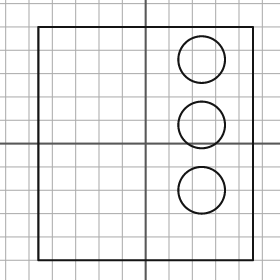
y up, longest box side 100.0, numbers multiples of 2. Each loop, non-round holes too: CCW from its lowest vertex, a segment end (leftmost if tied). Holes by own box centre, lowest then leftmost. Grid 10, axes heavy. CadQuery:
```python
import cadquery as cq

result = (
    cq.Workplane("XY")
    .moveTo(-46.0, -50.0)
    .lineTo(46.0, -50.0)
    .lineTo(46.0, 50.0)
    .lineTo(-46.0, 50.0)
    .close()
    .moveTo(24.0, -20.0)
    .circle(10.0)
    .moveTo(24.0, 8.0)
    .circle(10.0)
    .moveTo(24.0, 36.0)
    .circle(10.0)
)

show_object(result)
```